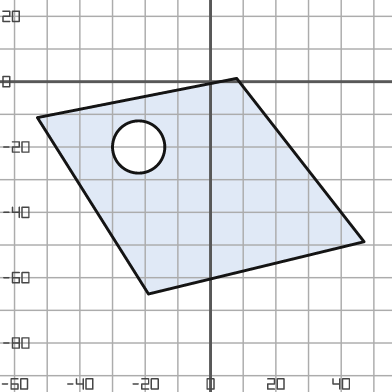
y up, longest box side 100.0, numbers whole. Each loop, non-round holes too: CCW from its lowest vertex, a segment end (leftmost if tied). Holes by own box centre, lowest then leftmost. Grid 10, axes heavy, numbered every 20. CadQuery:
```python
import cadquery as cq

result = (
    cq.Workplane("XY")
    .moveTo(-19.0, -65.0)
    .lineTo(47.0, -49.0)
    .lineTo(8.0, 1.0)
    .lineTo(-53.0, -11.0)
    .close()
    .moveTo(-22.0, -20.0)
    .circle(8.0)
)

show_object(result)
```